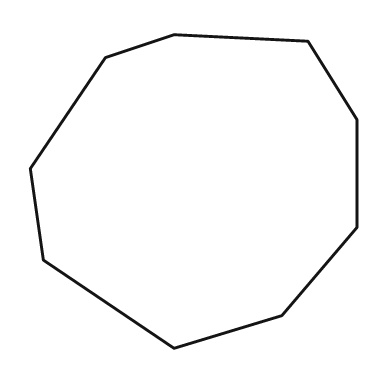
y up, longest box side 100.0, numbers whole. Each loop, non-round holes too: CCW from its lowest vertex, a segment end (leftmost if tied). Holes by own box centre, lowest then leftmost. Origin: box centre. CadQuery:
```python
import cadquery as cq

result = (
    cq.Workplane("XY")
    .moveTo(-6.0, -48.0)
    .lineTo(27.0, -38.0)
    .lineTo(50.0, -11.0)
    .lineTo(50.0, 22.0)
    .lineTo(35.0, 46.0)
    .lineTo(-6.0, 48.0)
    .lineTo(-27.0, 41.0)
    .lineTo(-50.0, 7.0)
    .lineTo(-46.0, -21.0)
    .close()
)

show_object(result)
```